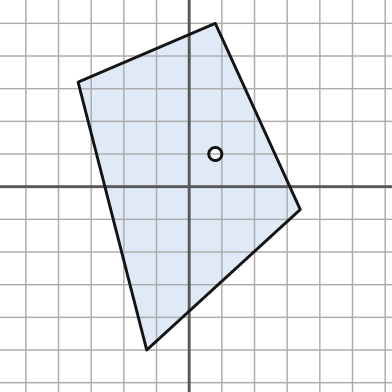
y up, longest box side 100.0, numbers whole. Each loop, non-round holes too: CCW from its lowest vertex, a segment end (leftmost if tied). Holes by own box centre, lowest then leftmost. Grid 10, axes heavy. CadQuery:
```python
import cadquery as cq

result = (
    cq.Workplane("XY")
    .moveTo(-13.0, -50.0)
    .lineTo(34.0, -7.0)
    .lineTo(8.0, 50.0)
    .lineTo(-34.0, 32.0)
    .close()
    .moveTo(8.0, 10.0)
    .circle(2.0)
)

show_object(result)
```